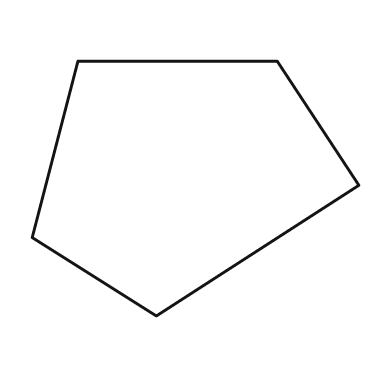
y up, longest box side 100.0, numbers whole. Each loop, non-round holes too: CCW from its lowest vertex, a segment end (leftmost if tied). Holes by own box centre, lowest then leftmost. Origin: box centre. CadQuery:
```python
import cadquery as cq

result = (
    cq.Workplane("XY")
    .moveTo(-12.0, -39.0)
    .lineTo(50.0, 1.0)
    .lineTo(25.0, 39.0)
    .lineTo(-36.0, 39.0)
    .lineTo(-50.0, -15.0)
    .close()
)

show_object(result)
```